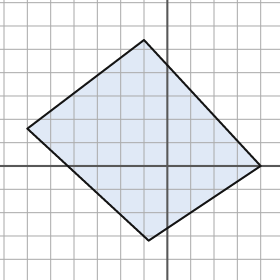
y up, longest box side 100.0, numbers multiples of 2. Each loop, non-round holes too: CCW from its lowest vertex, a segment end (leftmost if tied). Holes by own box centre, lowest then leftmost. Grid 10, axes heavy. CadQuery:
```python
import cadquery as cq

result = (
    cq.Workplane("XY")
    .moveTo(-8.0, -32.0)
    .lineTo(40.0, 0.0)
    .lineTo(-10.0, 54.0)
    .lineTo(-60.0, 16.0)
    .close()
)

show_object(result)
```